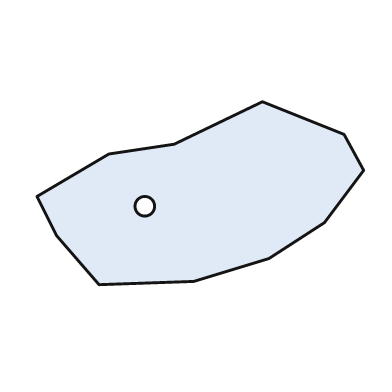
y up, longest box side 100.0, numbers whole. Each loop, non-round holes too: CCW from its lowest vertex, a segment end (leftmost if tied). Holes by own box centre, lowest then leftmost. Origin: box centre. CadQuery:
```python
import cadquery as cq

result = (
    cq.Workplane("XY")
    .moveTo(-31.0, -28.0)
    .lineTo(-2.0, -27.0)
    .lineTo(21.0, -20.0)
    .lineTo(38.0, -9.0)
    .lineTo(50.0, 7.0)
    .lineTo(44.0, 18.0)
    .lineTo(19.0, 28.0)
    .lineTo(-8.0, 15.0)
    .lineTo(-28.0, 12.0)
    .lineTo(-50.0, -1.0)
    .lineTo(-44.0, -13.0)
    .close()
    .moveTo(-17.0, -4.0)
    .circle(3.0)
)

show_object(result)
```